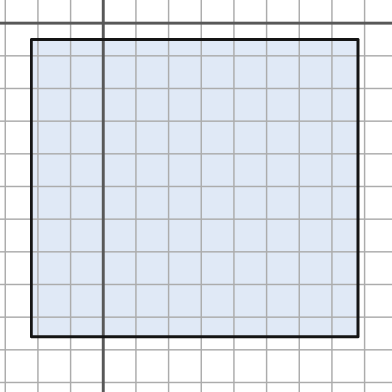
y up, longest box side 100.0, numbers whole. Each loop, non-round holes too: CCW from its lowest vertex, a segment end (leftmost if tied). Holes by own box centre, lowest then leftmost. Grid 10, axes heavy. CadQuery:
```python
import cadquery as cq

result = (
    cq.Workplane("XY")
    .moveTo(-22.0, -96.0)
    .lineTo(78.0, -96.0)
    .lineTo(78.0, -5.0)
    .lineTo(-22.0, -5.0)
    .close()
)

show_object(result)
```